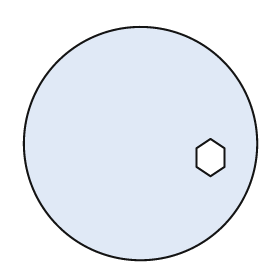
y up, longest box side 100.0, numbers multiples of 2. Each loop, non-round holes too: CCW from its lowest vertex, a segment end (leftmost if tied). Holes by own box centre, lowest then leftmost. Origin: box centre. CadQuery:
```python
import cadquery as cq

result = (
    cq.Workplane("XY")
    .moveTo(0.0, 0.0)
    .circle(50.0)
    .moveTo(30.0, -14.0)
    .lineTo(36.0, -10.0)
    .lineTo(36.0, -2.0)
    .lineTo(30.0, 2.0)
    .lineTo(24.0, -2.0)
    .lineTo(24.0, -10.0)
    .close()
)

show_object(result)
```